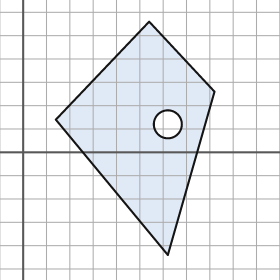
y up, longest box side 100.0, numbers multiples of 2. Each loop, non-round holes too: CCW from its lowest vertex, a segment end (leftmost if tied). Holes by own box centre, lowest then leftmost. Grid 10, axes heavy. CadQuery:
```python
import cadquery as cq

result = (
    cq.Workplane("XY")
    .moveTo(62.0, -44.0)
    .lineTo(82.0, 26.0)
    .lineTo(54.0, 56.0)
    .lineTo(14.0, 14.0)
    .close()
    .moveTo(62.0, 12.0)
    .circle(6.0)
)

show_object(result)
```